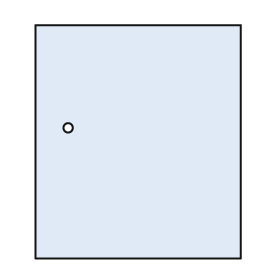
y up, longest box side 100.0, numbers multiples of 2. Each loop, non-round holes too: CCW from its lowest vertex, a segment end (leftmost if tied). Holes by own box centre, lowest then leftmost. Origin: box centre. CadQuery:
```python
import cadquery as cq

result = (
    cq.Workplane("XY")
    .moveTo(-44.0, -50.0)
    .lineTo(44.0, -50.0)
    .lineTo(44.0, 50.0)
    .lineTo(-44.0, 50.0)
    .close()
    .moveTo(-30.0, 6.0)
    .circle(2.0)
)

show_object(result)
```